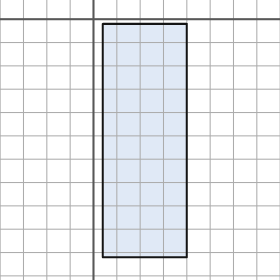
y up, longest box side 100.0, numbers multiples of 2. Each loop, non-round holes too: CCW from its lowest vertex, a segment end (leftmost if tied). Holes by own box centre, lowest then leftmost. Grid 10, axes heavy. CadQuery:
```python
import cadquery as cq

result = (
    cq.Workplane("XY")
    .moveTo(4.0, -102.0)
    .lineTo(40.0, -102.0)
    .lineTo(40.0, -2.0)
    .lineTo(4.0, -2.0)
    .close()
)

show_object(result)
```